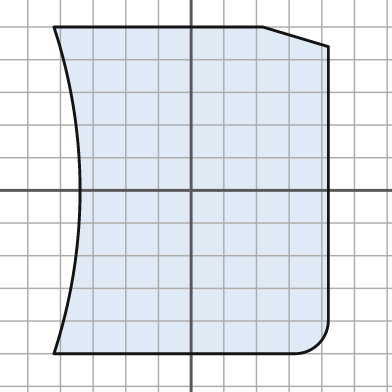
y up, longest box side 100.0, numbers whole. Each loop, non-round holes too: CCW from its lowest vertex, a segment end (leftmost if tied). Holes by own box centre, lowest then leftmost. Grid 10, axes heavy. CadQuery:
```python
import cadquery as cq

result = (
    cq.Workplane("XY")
    .moveTo(-42.0, -50.0)
    .lineTo(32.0, -50.0)
    .threePointArc((39.0, -47.0), (42.0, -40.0))
    .lineTo(42.0, 44.0)
    .lineTo(22.0, 50.0)
    .lineTo(-42.0, 50.0)
    .threePointArc((-34.0, 0.0), (-42.0, -50.0))
    .close()
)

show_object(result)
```